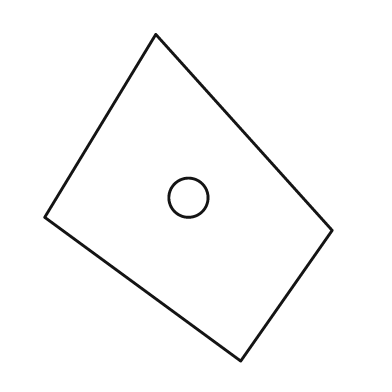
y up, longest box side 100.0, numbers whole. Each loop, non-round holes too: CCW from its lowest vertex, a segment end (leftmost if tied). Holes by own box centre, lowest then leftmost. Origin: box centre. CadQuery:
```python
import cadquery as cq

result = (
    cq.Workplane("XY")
    .moveTo(16.0, -50.0)
    .lineTo(44.0, -10.0)
    .lineTo(-10.0, 50.0)
    .lineTo(-44.0, -6.0)
    .close()
    .moveTo(0.0, 0.0)
    .circle(6.0)
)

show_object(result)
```